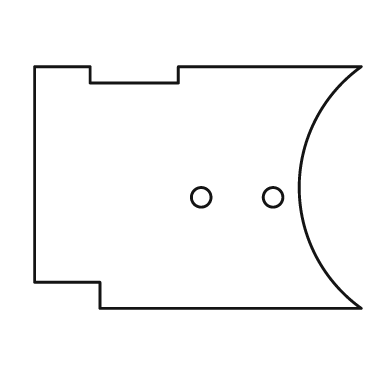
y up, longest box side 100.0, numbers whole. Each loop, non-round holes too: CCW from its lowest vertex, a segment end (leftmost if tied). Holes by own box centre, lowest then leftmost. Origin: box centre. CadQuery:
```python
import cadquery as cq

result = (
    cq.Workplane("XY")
    .moveTo(-30.0, -37.0)
    .lineTo(50.0, -37.0)
    .threePointArc((31.0, 0.0), (50.0, 37.0))
    .lineTo(-6.0, 37.0)
    .lineTo(-6.0, 32.0)
    .lineTo(-33.0, 32.0)
    .lineTo(-33.0, 37.0)
    .lineTo(-50.0, 37.0)
    .lineTo(-50.0, -29.0)
    .lineTo(-30.0, -29.0)
    .close()
    .moveTo(1.0, -3.0)
    .circle(3.0)
    .moveTo(23.0, -3.0)
    .circle(3.0)
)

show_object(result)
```